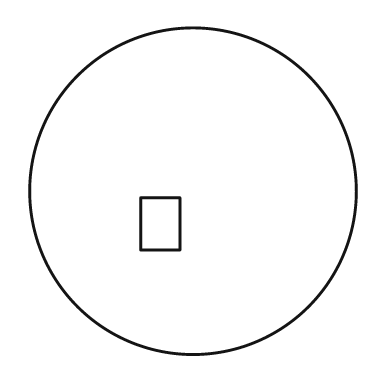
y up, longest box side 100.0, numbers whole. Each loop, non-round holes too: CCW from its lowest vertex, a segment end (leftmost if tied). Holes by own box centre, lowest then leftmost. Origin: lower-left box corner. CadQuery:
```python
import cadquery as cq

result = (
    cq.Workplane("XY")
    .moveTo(50.0, 50.0)
    .circle(50.0)
    .moveTo(34.0, 32.0)
    .lineTo(46.0, 32.0)
    .lineTo(46.0, 48.0)
    .lineTo(34.0, 48.0)
    .close()
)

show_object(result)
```